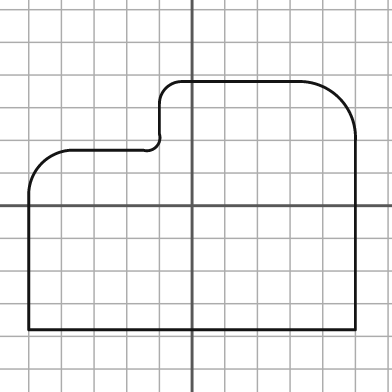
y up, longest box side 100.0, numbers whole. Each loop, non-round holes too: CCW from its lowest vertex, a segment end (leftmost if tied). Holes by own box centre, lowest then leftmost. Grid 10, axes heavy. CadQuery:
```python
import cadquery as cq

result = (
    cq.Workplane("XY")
    .moveTo(-50.0, -38.0)
    .lineTo(50.0, -38.0)
    .lineTo(50.0, 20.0)
    .threePointArc((45.0, 33.0), (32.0, 38.0))
    .lineTo(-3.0, 38.0)
    .threePointArc((-8.0, 36.0), (-10.0, 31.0))
    .lineTo(-10.0, 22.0)
    .threePointArc((-11.0, 18.0), (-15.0, 17.0))
    .lineTo(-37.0, 17.0)
    .threePointArc((-46.0, 13.0), (-50.0, 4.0))
    .close()
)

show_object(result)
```